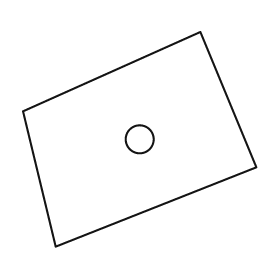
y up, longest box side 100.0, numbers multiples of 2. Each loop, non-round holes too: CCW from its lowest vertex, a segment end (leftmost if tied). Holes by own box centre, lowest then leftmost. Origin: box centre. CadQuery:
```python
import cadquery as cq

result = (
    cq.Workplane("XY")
    .moveTo(-36.0, -46.0)
    .lineTo(50.0, -12.0)
    .lineTo(26.0, 46.0)
    .lineTo(-50.0, 12.0)
    .close()
    .moveTo(0.0, 0.0)
    .circle(6.0)
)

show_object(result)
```